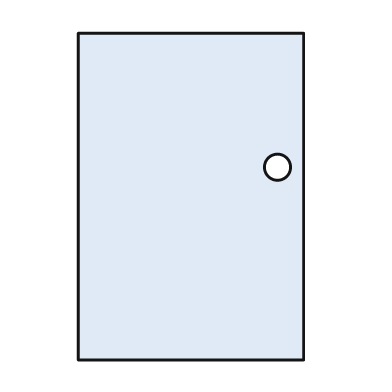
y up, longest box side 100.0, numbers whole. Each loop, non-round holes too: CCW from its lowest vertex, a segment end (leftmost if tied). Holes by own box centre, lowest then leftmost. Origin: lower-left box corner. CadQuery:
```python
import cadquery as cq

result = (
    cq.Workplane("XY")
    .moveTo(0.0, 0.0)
    .lineTo(69.0, 0.0)
    .lineTo(69.0, 100.0)
    .lineTo(0.0, 100.0)
    .close()
    .moveTo(61.0, 59.0)
    .circle(4.0)
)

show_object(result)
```